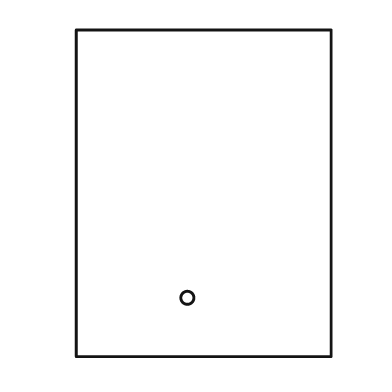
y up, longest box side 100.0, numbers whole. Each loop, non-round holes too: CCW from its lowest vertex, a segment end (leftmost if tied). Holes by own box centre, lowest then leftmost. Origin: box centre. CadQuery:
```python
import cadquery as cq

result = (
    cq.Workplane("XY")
    .moveTo(-39.0, -50.0)
    .lineTo(39.0, -50.0)
    .lineTo(39.0, 50.0)
    .lineTo(-39.0, 50.0)
    .close()
    .moveTo(-5.0, -32.0)
    .circle(2.0)
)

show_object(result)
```